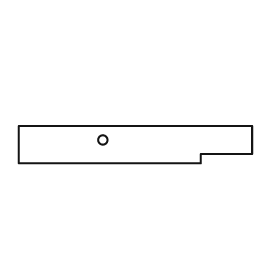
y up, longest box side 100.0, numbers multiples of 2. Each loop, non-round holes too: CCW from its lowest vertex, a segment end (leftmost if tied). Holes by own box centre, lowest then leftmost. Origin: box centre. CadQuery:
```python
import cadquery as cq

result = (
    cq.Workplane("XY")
    .moveTo(-50.0, -8.0)
    .lineTo(28.0, -8.0)
    .lineTo(28.0, -4.0)
    .lineTo(50.0, -4.0)
    .lineTo(50.0, 8.0)
    .lineTo(-50.0, 8.0)
    .close()
    .moveTo(-14.0, 2.0)
    .circle(2.0)
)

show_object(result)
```